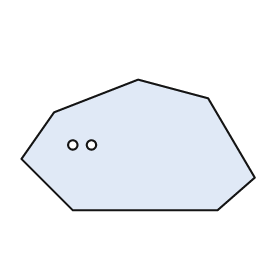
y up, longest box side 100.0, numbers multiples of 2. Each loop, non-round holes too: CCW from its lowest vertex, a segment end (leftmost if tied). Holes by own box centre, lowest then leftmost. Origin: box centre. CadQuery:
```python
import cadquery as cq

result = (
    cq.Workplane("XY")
    .moveTo(-28.0, -28.0)
    .lineTo(34.0, -28.0)
    .lineTo(50.0, -14.0)
    .lineTo(30.0, 20.0)
    .lineTo(0.0, 28.0)
    .lineTo(-36.0, 14.0)
    .lineTo(-50.0, -6.0)
    .close()
    .moveTo(-28.0, 0.0)
    .circle(2.0)
    .moveTo(-20.0, 0.0)
    .circle(2.0)
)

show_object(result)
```